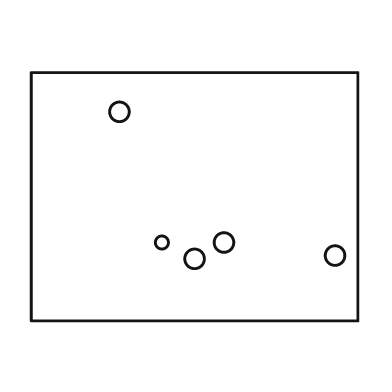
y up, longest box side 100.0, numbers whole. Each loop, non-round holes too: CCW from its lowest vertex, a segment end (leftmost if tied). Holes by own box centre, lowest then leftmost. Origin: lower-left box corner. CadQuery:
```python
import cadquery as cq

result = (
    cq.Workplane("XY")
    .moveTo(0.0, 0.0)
    .lineTo(100.0, 0.0)
    .lineTo(100.0, 76.0)
    .lineTo(0.0, 76.0)
    .close()
    .moveTo(50.0, 19.0)
    .circle(3.0)
    .moveTo(93.0, 20.0)
    .circle(3.0)
    .moveTo(40.0, 24.0)
    .circle(2.0)
    .moveTo(59.0, 24.0)
    .circle(3.0)
    .moveTo(27.0, 64.0)
    .circle(3.0)
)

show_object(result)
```